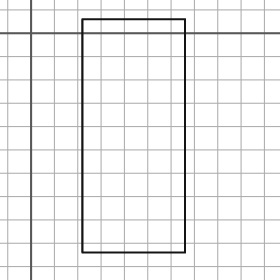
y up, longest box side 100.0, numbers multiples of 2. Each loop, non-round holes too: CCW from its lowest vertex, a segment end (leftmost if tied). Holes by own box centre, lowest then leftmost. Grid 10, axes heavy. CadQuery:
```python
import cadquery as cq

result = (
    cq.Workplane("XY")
    .moveTo(22.0, -94.0)
    .lineTo(66.0, -94.0)
    .lineTo(66.0, 6.0)
    .lineTo(22.0, 6.0)
    .close()
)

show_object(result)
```